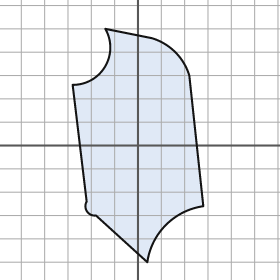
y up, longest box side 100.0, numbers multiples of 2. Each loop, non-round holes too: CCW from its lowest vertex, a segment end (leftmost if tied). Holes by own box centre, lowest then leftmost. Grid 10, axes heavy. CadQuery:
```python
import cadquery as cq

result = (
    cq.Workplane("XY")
    .moveTo(4.0, -50.0)
    .threePointArc((12.0, -34.0), (28.0, -26.0))
    .lineTo(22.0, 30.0)
    .threePointArc((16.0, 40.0), (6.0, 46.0))
    .lineTo(-14.0, 50.0)
    .threePointArc((-14.0, 34.0), (-28.0, 26.0))
    .lineTo(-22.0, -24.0)
    .threePointArc((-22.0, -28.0), (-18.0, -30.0))
    .close()
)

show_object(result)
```